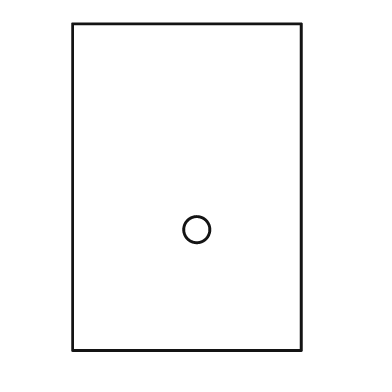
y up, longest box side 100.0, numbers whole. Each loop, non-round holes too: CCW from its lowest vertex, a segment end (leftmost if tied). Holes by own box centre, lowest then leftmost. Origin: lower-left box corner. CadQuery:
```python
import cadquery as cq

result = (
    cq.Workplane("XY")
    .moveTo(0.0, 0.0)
    .lineTo(70.0, 0.0)
    .lineTo(70.0, 100.0)
    .lineTo(0.0, 100.0)
    .close()
    .moveTo(38.0, 37.0)
    .circle(4.0)
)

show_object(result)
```